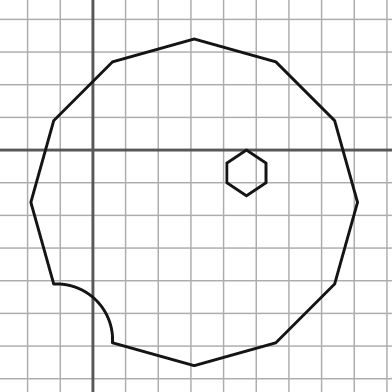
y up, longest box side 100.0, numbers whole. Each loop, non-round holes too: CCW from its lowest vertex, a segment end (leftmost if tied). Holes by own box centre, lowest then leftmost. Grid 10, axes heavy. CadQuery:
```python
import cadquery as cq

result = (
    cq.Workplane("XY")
    .moveTo(31.0, -66.0)
    .lineTo(56.0, -59.0)
    .lineTo(74.0, -41.0)
    .lineTo(81.0, -16.0)
    .lineTo(74.0, 9.0)
    .lineTo(56.0, 27.0)
    .lineTo(31.0, 34.0)
    .lineTo(6.0, 27.0)
    .lineTo(-12.0, 9.0)
    .lineTo(-19.0, -16.0)
    .lineTo(-12.0, -41.0)
    .threePointArc((1.0, -46.0), (6.0, -59.0))
    .close()
    .moveTo(47.0, -14.0)
    .lineTo(53.0, -10.0)
    .lineTo(53.0, -4.0)
    .lineTo(47.0, 0.0)
    .lineTo(41.0, -4.0)
    .lineTo(41.0, -10.0)
    .close()
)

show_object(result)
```